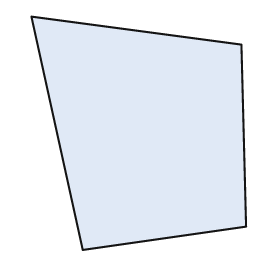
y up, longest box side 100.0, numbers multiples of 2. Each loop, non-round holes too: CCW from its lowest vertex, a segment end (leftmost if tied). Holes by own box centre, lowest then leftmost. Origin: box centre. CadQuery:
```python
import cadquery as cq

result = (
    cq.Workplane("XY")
    .moveTo(-24.0, -50.0)
    .lineTo(46.0, -40.0)
    .lineTo(44.0, 38.0)
    .lineTo(-46.0, 50.0)
    .close()
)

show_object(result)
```